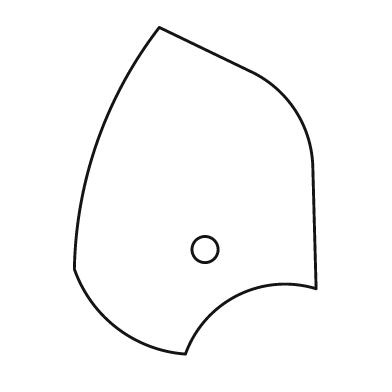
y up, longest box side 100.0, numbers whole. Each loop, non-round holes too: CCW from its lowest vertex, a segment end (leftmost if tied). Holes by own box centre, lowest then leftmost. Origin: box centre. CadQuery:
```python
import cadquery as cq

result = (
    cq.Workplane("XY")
    .moveTo(-3.0, -50.0)
    .threePointArc((13.0, -32.0), (37.0, -30.0))
    .lineTo(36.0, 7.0)
    .threePointArc((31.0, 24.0), (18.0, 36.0))
    .lineTo(-11.0, 50.0)
    .threePointArc((-30.0, 15.0), (-37.0, -24.0))
    .threePointArc((-24.0, -42.0), (-3.0, -50.0))
    .close()
    .moveTo(3.0, -18.0)
    .circle(4.0)
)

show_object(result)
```